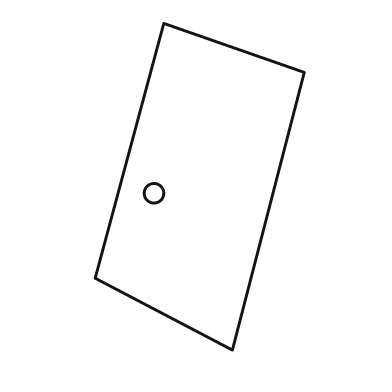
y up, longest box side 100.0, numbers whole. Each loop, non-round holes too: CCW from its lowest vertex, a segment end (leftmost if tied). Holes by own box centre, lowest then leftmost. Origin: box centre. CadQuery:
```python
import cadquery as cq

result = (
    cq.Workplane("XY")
    .moveTo(10.0, -50.0)
    .lineTo(32.0, 35.0)
    .lineTo(-11.0, 50.0)
    .lineTo(-32.0, -28.0)
    .close()
    .moveTo(-14.0, -2.0)
    .circle(3.0)
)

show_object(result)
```